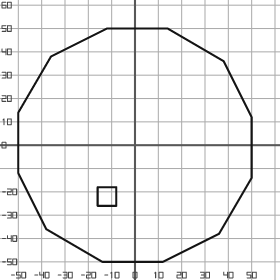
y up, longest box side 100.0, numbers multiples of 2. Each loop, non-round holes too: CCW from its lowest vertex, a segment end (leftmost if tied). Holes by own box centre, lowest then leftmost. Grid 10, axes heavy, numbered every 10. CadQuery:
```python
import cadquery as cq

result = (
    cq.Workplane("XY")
    .moveTo(-14.0, -50.0)
    .lineTo(12.0, -50.0)
    .lineTo(36.0, -38.0)
    .lineTo(50.0, -14.0)
    .lineTo(50.0, 12.0)
    .lineTo(38.0, 36.0)
    .lineTo(14.0, 50.0)
    .lineTo(-12.0, 50.0)
    .lineTo(-36.0, 38.0)
    .lineTo(-50.0, 14.0)
    .lineTo(-50.0, -12.0)
    .lineTo(-38.0, -36.0)
    .close()
    .moveTo(-16.0, -26.0)
    .lineTo(-8.0, -26.0)
    .lineTo(-8.0, -18.0)
    .lineTo(-16.0, -18.0)
    .close()
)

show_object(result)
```